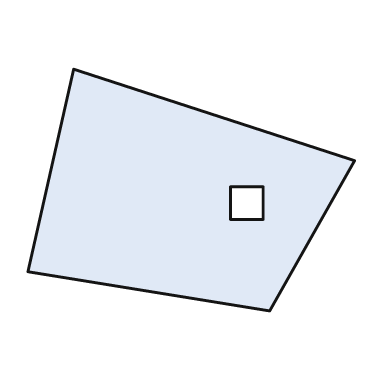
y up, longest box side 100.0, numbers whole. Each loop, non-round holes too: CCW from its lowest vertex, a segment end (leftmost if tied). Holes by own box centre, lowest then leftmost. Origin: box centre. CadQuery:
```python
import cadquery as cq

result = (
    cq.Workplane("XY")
    .moveTo(24.0, -37.0)
    .lineTo(50.0, 9.0)
    .lineTo(-36.0, 37.0)
    .lineTo(-50.0, -25.0)
    .close()
    .moveTo(12.0, -9.0)
    .lineTo(22.0, -9.0)
    .lineTo(22.0, 1.0)
    .lineTo(12.0, 1.0)
    .close()
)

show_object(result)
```